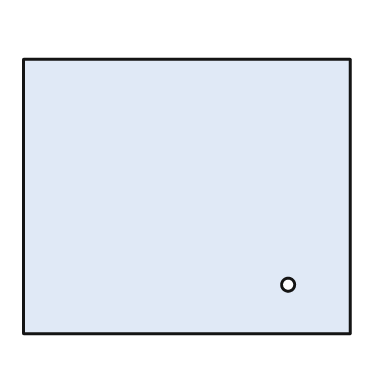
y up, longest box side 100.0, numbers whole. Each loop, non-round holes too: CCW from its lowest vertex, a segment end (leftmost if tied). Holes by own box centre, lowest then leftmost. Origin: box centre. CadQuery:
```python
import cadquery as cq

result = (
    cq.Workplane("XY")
    .moveTo(-50.0, -42.0)
    .lineTo(50.0, -42.0)
    .lineTo(50.0, 42.0)
    .lineTo(-50.0, 42.0)
    .close()
    .moveTo(31.0, -27.0)
    .circle(2.0)
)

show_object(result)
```